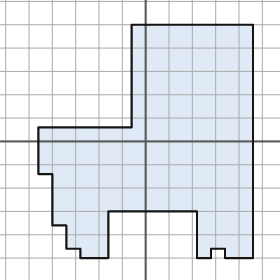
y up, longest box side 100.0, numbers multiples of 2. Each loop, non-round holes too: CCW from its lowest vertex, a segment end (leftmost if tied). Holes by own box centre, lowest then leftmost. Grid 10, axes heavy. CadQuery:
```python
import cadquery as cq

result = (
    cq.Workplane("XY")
    .moveTo(-28.0, -50.0)
    .lineTo(-16.0, -50.0)
    .lineTo(-16.0, -30.0)
    .lineTo(22.0, -30.0)
    .lineTo(22.0, -50.0)
    .lineTo(28.0, -50.0)
    .lineTo(28.0, -46.0)
    .lineTo(34.0, -46.0)
    .lineTo(34.0, -50.0)
    .lineTo(46.0, -50.0)
    .lineTo(46.0, 50.0)
    .lineTo(-6.0, 50.0)
    .lineTo(-6.0, 6.0)
    .lineTo(-46.0, 6.0)
    .lineTo(-46.0, -14.0)
    .lineTo(-40.0, -14.0)
    .lineTo(-40.0, -36.0)
    .lineTo(-34.0, -36.0)
    .lineTo(-34.0, -46.0)
    .lineTo(-28.0, -46.0)
    .close()
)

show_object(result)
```